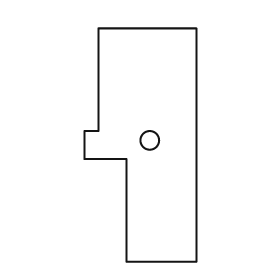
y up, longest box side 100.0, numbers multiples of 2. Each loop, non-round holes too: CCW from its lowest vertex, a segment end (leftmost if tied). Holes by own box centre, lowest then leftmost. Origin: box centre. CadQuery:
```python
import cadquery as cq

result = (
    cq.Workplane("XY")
    .moveTo(-6.0, -50.0)
    .lineTo(24.0, -50.0)
    .lineTo(24.0, 50.0)
    .lineTo(-18.0, 50.0)
    .lineTo(-18.0, 6.0)
    .lineTo(-24.0, 6.0)
    .lineTo(-24.0, -6.0)
    .lineTo(-6.0, -6.0)
    .close()
    .moveTo(4.0, 2.0)
    .circle(4.0)
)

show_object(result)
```